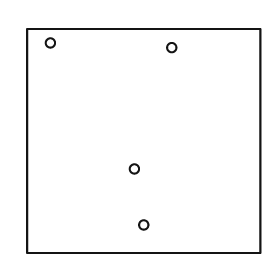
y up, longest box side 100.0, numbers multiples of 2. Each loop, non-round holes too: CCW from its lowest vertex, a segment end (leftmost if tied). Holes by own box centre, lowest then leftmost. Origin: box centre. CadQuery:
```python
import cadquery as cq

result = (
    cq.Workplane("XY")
    .moveTo(-50.0, -48.0)
    .lineTo(50.0, -48.0)
    .lineTo(50.0, 48.0)
    .lineTo(-50.0, 48.0)
    .close()
    .moveTo(0.0, -36.0)
    .circle(2.0)
    .moveTo(-4.0, -12.0)
    .circle(2.0)
    .moveTo(12.0, 40.0)
    .circle(2.0)
    .moveTo(-40.0, 42.0)
    .circle(2.0)
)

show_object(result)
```